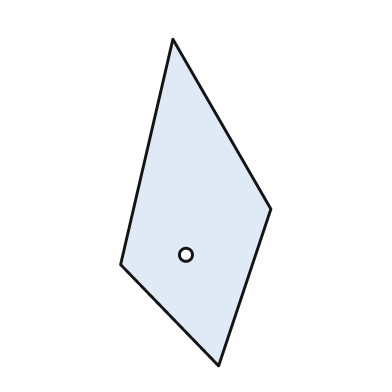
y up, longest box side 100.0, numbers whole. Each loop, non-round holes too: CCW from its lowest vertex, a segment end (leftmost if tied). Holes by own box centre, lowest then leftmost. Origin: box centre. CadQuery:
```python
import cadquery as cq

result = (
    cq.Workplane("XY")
    .moveTo(7.0, -50.0)
    .lineTo(23.0, -2.0)
    .lineTo(-7.0, 50.0)
    .lineTo(-23.0, -19.0)
    .close()
    .moveTo(-3.0, -16.0)
    .circle(2.0)
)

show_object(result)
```